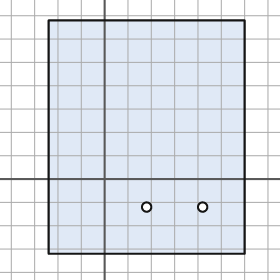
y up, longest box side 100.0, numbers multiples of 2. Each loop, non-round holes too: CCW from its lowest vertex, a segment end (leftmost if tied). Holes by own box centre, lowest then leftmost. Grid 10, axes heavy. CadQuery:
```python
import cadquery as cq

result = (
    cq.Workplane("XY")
    .moveTo(-24.0, -32.0)
    .lineTo(60.0, -32.0)
    .lineTo(60.0, 68.0)
    .lineTo(-24.0, 68.0)
    .close()
    .moveTo(18.0, -12.0)
    .circle(2.0)
    .moveTo(42.0, -12.0)
    .circle(2.0)
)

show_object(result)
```